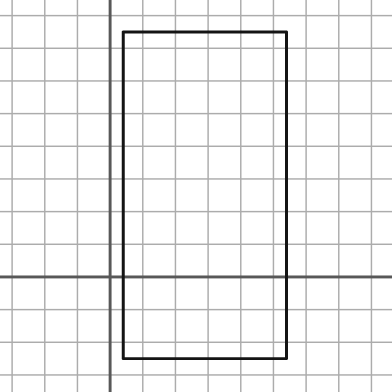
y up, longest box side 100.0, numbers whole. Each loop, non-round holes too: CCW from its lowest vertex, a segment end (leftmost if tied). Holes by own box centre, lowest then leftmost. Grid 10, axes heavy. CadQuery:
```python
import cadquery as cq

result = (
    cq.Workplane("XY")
    .moveTo(4.0, -25.0)
    .lineTo(54.0, -25.0)
    .lineTo(54.0, 75.0)
    .lineTo(4.0, 75.0)
    .close()
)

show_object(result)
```